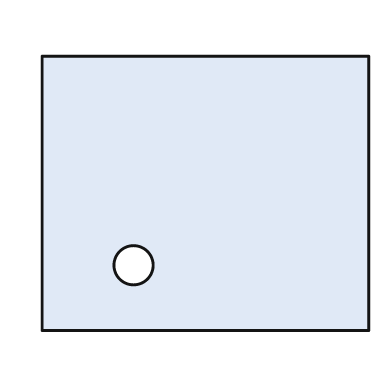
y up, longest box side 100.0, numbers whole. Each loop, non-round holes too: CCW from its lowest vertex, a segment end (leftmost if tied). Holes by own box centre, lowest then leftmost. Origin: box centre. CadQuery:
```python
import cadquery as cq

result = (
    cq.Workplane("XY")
    .moveTo(-50.0, -42.0)
    .lineTo(50.0, -42.0)
    .lineTo(50.0, 42.0)
    .lineTo(-50.0, 42.0)
    .close()
    .moveTo(-22.0, -22.0)
    .circle(6.0)
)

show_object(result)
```